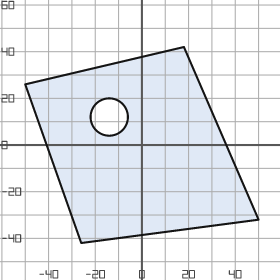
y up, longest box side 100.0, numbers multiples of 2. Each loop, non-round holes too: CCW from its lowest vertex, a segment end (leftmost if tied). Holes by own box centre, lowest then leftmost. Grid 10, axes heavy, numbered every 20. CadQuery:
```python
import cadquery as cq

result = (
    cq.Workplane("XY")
    .moveTo(-26.0, -42.0)
    .lineTo(50.0, -32.0)
    .lineTo(18.0, 42.0)
    .lineTo(-50.0, 26.0)
    .close()
    .moveTo(-14.0, 12.0)
    .circle(8.0)
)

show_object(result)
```